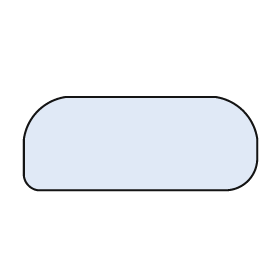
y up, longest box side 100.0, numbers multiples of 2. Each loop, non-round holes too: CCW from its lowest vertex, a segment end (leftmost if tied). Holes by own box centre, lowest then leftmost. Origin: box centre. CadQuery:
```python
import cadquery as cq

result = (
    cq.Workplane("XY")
    .moveTo(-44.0, -20.0)
    .lineTo(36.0, -20.0)
    .threePointArc((46.0, -16.0), (50.0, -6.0))
    .lineTo(50.0, 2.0)
    .threePointArc((44.0, 14.0), (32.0, 20.0))
    .lineTo(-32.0, 20.0)
    .threePointArc((-44.0, 14.0), (-50.0, 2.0))
    .lineTo(-50.0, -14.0)
    .threePointArc((-48.0, -18.0), (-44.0, -20.0))
    .close()
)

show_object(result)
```